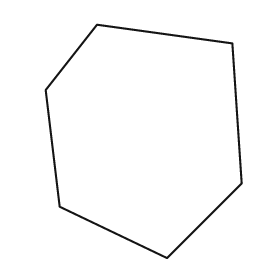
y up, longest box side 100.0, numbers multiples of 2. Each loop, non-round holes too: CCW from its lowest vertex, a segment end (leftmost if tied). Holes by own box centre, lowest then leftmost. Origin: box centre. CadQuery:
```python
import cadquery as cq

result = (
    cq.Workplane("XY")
    .moveTo(10.0, -50.0)
    .lineTo(42.0, -18.0)
    .lineTo(38.0, 42.0)
    .lineTo(-20.0, 50.0)
    .lineTo(-42.0, 22.0)
    .lineTo(-36.0, -28.0)
    .close()
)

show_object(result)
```